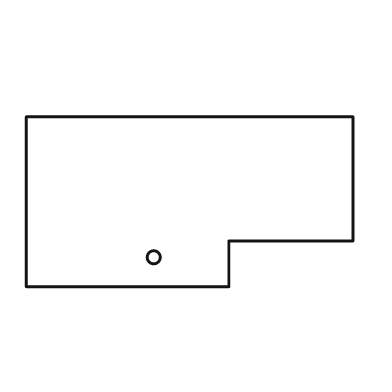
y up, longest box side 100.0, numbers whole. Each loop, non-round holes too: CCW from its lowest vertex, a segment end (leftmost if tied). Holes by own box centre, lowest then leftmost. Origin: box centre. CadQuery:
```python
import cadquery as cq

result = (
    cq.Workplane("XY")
    .moveTo(-50.0, -26.0)
    .lineTo(12.0, -26.0)
    .lineTo(12.0, -12.0)
    .lineTo(50.0, -12.0)
    .lineTo(50.0, 26.0)
    .lineTo(-50.0, 26.0)
    .close()
    .moveTo(-11.0, -17.0)
    .circle(2.0)
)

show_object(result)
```